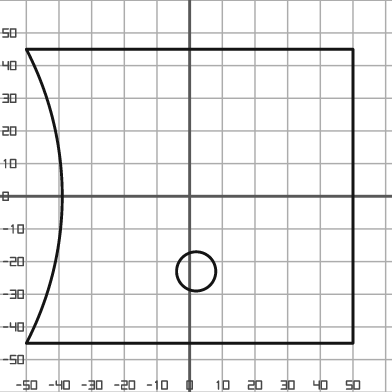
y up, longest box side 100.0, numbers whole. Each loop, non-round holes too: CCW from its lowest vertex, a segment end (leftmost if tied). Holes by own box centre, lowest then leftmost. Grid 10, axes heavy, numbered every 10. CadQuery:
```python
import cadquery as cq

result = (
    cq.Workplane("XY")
    .moveTo(-50.0, -45.0)
    .lineTo(50.0, -45.0)
    .lineTo(50.0, 45.0)
    .lineTo(-50.0, 45.0)
    .threePointArc((-39.0, 0.0), (-50.0, -45.0))
    .close()
    .moveTo(2.0, -23.0)
    .circle(6.0)
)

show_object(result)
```